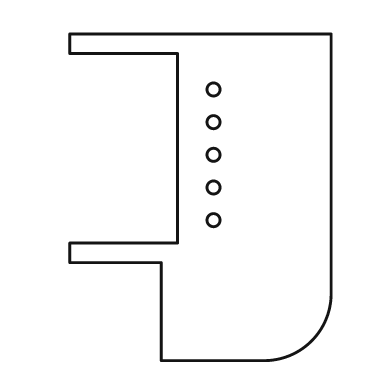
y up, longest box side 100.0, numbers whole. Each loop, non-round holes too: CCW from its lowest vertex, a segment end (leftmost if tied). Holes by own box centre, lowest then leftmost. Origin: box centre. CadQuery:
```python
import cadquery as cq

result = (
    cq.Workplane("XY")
    .moveTo(-12.0, -50.0)
    .lineTo(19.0, -50.0)
    .threePointArc((34.0, -44.0), (40.0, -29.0))
    .lineTo(40.0, 50.0)
    .lineTo(-40.0, 50.0)
    .lineTo(-40.0, 44.0)
    .lineTo(-7.0, 44.0)
    .lineTo(-7.0, -14.0)
    .lineTo(-40.0, -14.0)
    .lineTo(-40.0, -20.0)
    .lineTo(-12.0, -20.0)
    .close()
    .moveTo(4.0, -7.0)
    .circle(2.0)
    .moveTo(4.0, 3.0)
    .circle(2.0)
    .moveTo(4.0, 13.0)
    .circle(2.0)
    .moveTo(4.0, 23.0)
    .circle(2.0)
    .moveTo(4.0, 33.0)
    .circle(2.0)
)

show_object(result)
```